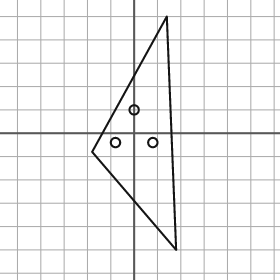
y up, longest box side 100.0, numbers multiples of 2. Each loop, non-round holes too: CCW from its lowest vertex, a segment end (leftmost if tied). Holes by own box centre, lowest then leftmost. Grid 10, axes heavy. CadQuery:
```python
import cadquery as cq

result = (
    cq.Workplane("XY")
    .moveTo(18.0, -50.0)
    .lineTo(14.0, 50.0)
    .lineTo(-18.0, -8.0)
    .close()
    .moveTo(-8.0, -4.0)
    .circle(2.0)
    .moveTo(8.0, -4.0)
    .circle(2.0)
    .moveTo(0.0, 10.0)
    .circle(2.0)
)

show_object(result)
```